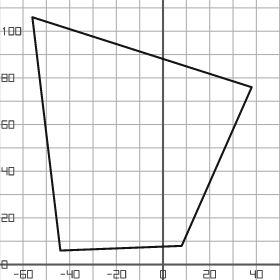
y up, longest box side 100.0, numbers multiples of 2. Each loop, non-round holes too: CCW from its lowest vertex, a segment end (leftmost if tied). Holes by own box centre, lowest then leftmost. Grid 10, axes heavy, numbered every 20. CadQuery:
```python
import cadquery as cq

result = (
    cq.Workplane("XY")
    .moveTo(-44.0, 6.0)
    .lineTo(8.0, 8.0)
    .lineTo(38.0, 76.0)
    .lineTo(-56.0, 106.0)
    .close()
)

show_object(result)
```